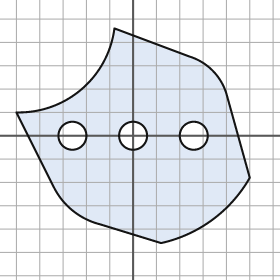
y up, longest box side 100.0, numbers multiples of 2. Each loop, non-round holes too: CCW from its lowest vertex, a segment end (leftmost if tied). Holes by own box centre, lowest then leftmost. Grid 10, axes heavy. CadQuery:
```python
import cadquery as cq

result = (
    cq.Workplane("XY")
    .moveTo(12.0, -46.0)
    .threePointArc((34.0, -36.0), (50.0, -18.0))
    .lineTo(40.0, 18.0)
    .threePointArc((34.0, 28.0), (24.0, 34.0))
    .lineTo(-8.0, 46.0)
    .threePointArc((-22.0, 20.0), (-50.0, 10.0))
    .lineTo(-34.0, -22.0)
    .threePointArc((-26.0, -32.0), (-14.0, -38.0))
    .close()
    .moveTo(-26.0, 0.0)
    .circle(6.0)
    .moveTo(0.0, 0.0)
    .circle(6.0)
    .moveTo(26.0, 0.0)
    .circle(6.0)
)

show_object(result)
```